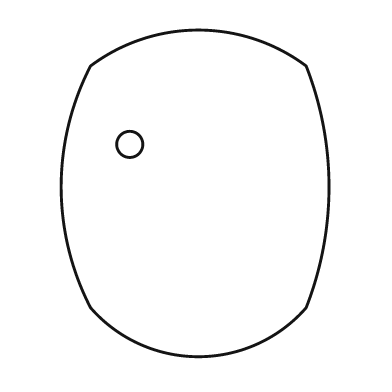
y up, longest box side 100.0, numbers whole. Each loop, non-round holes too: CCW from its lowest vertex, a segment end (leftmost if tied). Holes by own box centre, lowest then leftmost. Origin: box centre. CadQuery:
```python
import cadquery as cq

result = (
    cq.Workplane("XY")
    .moveTo(-32.0, -35.0)
    .threePointArc((1.0, -50.0), (34.0, -35.0))
    .threePointArc((41.0, 2.0), (34.0, 39.0))
    .threePointArc((1.0, 50.0), (-32.0, 39.0))
    .threePointArc((-41.0, 2.0), (-32.0, -35.0))
    .close()
    .moveTo(-20.0, 15.0)
    .circle(4.0)
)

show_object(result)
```